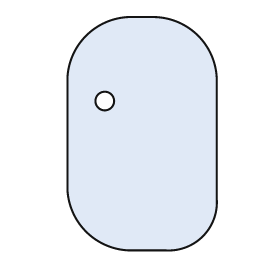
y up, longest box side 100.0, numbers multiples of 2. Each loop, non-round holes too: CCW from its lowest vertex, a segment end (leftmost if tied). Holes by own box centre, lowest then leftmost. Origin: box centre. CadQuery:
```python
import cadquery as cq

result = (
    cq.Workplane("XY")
    .moveTo(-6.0, -50.0)
    .lineTo(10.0, -50.0)
    .threePointArc((26.0, -44.0), (32.0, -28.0))
    .lineTo(32.0, 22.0)
    .threePointArc((24.0, 42.0), (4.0, 50.0))
    .lineTo(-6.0, 50.0)
    .threePointArc((-24.0, 42.0), (-32.0, 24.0))
    .lineTo(-32.0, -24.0)
    .threePointArc((-24.0, -42.0), (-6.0, -50.0))
    .close()
    .moveTo(-16.0, 14.0)
    .circle(4.0)
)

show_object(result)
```